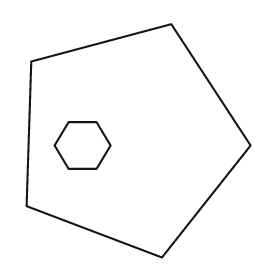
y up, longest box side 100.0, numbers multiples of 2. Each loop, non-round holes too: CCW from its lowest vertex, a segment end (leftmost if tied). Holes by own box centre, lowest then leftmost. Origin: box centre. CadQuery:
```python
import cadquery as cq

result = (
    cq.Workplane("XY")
    .moveTo(10.0, -50.0)
    .lineTo(48.0, -2.0)
    .lineTo(14.0, 50.0)
    .lineTo(-46.0, 34.0)
    .lineTo(-48.0, -28.0)
    .close()
    .moveTo(-30.0, -12.0)
    .lineTo(-18.0, -12.0)
    .lineTo(-12.0, -2.0)
    .lineTo(-18.0, 8.0)
    .lineTo(-30.0, 8.0)
    .lineTo(-36.0, -2.0)
    .close()
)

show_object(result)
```